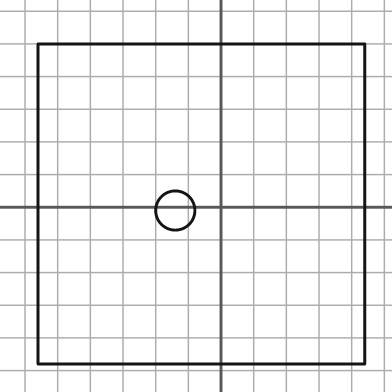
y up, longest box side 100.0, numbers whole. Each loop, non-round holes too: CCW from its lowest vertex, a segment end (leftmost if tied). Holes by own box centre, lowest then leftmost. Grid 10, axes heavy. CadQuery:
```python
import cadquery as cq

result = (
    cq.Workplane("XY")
    .moveTo(-56.0, -48.0)
    .lineTo(44.0, -48.0)
    .lineTo(44.0, 50.0)
    .lineTo(-56.0, 50.0)
    .close()
    .moveTo(-14.0, -1.0)
    .circle(6.0)
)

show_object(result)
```